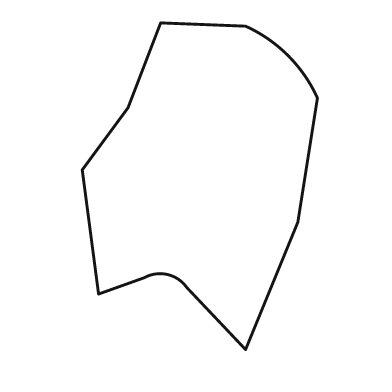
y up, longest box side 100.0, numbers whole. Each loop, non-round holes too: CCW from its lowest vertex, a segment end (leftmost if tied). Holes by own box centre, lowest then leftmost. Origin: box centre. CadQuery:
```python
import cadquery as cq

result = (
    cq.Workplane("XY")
    .moveTo(14.0, -50.0)
    .lineTo(30.0, -11.0)
    .lineTo(36.0, 27.0)
    .threePointArc((27.0, 40.0), (14.0, 49.0))
    .lineTo(-12.0, 50.0)
    .lineTo(-22.0, 24.0)
    .lineTo(-36.0, 5.0)
    .lineTo(-31.0, -33.0)
    .lineTo(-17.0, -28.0)
    .threePointArc((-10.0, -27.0), (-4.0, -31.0))
    .close()
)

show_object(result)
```